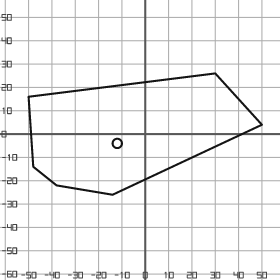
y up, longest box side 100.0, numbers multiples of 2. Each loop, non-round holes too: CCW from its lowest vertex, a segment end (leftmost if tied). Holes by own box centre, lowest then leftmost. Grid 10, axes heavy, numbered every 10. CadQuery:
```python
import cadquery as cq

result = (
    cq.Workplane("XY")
    .moveTo(-14.0, -26.0)
    .lineTo(50.0, 4.0)
    .lineTo(30.0, 26.0)
    .lineTo(-50.0, 16.0)
    .lineTo(-48.0, -14.0)
    .lineTo(-38.0, -22.0)
    .close()
    .moveTo(-12.0, -4.0)
    .circle(2.0)
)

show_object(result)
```